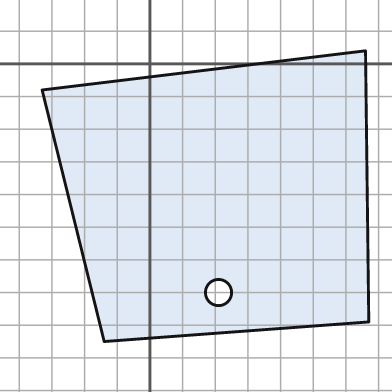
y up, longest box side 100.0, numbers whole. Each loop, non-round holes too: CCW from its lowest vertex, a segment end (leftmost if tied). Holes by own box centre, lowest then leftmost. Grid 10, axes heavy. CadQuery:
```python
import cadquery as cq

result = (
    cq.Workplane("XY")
    .moveTo(-14.0, -85.0)
    .lineTo(67.0, -79.0)
    .lineTo(66.0, 4.0)
    .lineTo(-33.0, -8.0)
    .close()
    .moveTo(21.0, -70.0)
    .circle(4.0)
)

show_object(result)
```